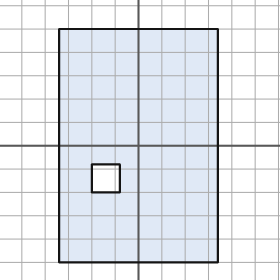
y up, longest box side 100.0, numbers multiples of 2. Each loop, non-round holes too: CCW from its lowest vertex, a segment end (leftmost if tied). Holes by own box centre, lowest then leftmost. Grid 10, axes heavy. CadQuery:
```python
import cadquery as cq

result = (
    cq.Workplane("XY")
    .moveTo(-34.0, -50.0)
    .lineTo(34.0, -50.0)
    .lineTo(34.0, 50.0)
    .lineTo(-34.0, 50.0)
    .close()
    .moveTo(-20.0, -20.0)
    .lineTo(-8.0, -20.0)
    .lineTo(-8.0, -8.0)
    .lineTo(-20.0, -8.0)
    .close()
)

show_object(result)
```